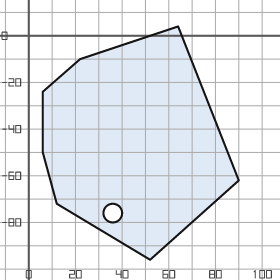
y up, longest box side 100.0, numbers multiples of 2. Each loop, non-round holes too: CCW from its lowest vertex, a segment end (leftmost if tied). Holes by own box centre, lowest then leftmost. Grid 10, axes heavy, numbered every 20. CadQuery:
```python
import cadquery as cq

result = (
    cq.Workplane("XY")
    .moveTo(52.0, -96.0)
    .lineTo(90.0, -62.0)
    .lineTo(64.0, 4.0)
    .lineTo(22.0, -10.0)
    .lineTo(6.0, -24.0)
    .lineTo(6.0, -50.0)
    .lineTo(12.0, -72.0)
    .close()
    .moveTo(36.0, -76.0)
    .circle(4.0)
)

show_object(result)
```